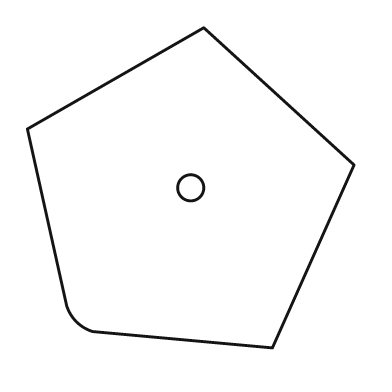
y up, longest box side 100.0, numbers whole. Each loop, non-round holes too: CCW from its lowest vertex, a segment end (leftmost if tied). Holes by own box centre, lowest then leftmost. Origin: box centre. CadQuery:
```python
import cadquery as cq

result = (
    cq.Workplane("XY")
    .moveTo(25.0, -49.0)
    .lineTo(50.0, 7.0)
    .lineTo(4.0, 49.0)
    .lineTo(-50.0, 18.0)
    .lineTo(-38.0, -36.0)
    .threePointArc((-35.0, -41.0), (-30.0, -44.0))
    .close()
    .moveTo(0.0, 0.0)
    .circle(4.0)
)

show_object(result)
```